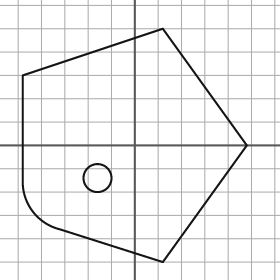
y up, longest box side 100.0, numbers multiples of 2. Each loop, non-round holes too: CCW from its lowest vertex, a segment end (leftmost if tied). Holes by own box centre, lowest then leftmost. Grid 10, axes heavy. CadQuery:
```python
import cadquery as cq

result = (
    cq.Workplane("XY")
    .moveTo(12.0, -50.0)
    .lineTo(48.0, 0.0)
    .lineTo(12.0, 50.0)
    .lineTo(-48.0, 30.0)
    .lineTo(-48.0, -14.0)
    .threePointArc((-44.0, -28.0), (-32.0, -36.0))
    .close()
    .moveTo(-16.0, -14.0)
    .circle(6.0)
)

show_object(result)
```